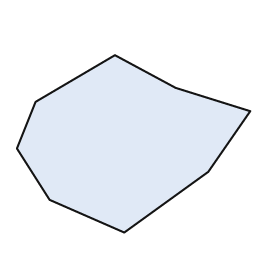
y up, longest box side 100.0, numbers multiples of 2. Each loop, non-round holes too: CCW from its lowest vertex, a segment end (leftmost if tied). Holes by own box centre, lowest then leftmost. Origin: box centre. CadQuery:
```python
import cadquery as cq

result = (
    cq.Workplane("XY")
    .moveTo(-4.0, -38.0)
    .lineTo(32.0, -12.0)
    .lineTo(50.0, 14.0)
    .lineTo(18.0, 24.0)
    .lineTo(-8.0, 38.0)
    .lineTo(-42.0, 18.0)
    .lineTo(-50.0, -2.0)
    .lineTo(-36.0, -24.0)
    .close()
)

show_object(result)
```